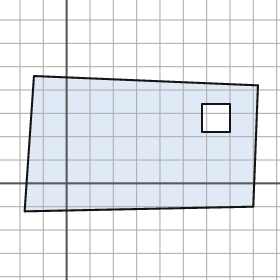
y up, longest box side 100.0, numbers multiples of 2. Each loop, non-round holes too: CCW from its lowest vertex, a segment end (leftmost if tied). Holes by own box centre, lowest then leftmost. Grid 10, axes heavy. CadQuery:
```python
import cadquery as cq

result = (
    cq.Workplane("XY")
    .moveTo(-18.0, -12.0)
    .lineTo(80.0, -10.0)
    .lineTo(82.0, 42.0)
    .lineTo(-14.0, 46.0)
    .close()
    .moveTo(58.0, 22.0)
    .lineTo(70.0, 22.0)
    .lineTo(70.0, 34.0)
    .lineTo(58.0, 34.0)
    .close()
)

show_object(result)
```